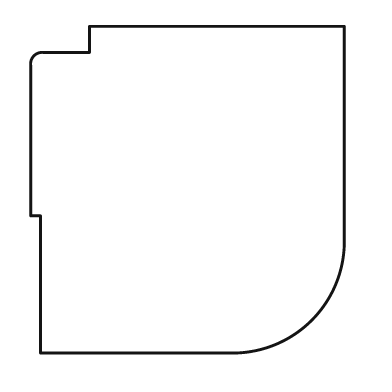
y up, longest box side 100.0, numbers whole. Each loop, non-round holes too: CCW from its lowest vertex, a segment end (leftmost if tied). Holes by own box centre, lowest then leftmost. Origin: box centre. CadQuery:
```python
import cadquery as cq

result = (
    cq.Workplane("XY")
    .moveTo(-45.0, -50.0)
    .lineTo(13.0, -50.0)
    .threePointArc((38.0, -40.0), (48.0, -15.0))
    .lineTo(48.0, 50.0)
    .lineTo(-30.0, 50.0)
    .lineTo(-30.0, 42.0)
    .lineTo(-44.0, 42.0)
    .threePointArc((-47.0, 41.0), (-48.0, 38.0))
    .lineTo(-48.0, -8.0)
    .lineTo(-45.0, -8.0)
    .close()
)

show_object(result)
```